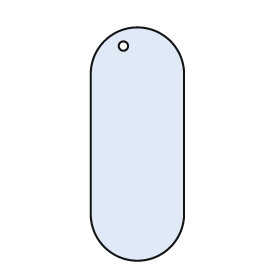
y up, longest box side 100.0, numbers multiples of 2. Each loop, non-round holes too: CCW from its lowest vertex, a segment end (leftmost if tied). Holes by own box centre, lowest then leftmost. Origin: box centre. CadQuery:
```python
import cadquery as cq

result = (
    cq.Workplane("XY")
    .moveTo(-20.0, -30.0)
    .threePointArc((0.0, -50.0), (20.0, -30.0))
    .lineTo(20.0, 30.0)
    .threePointArc((0.0, 50.0), (-20.0, 30.0))
    .close()
    .moveTo(-6.0, 42.0)
    .circle(2.0)
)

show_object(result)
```